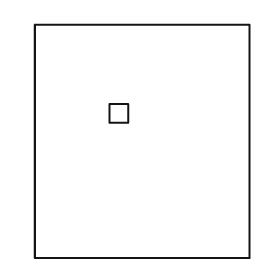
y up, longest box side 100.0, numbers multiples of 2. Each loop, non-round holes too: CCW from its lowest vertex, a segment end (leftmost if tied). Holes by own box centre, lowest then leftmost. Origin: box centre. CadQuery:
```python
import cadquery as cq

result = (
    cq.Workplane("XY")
    .moveTo(-46.0, -50.0)
    .lineTo(46.0, -50.0)
    .lineTo(46.0, 50.0)
    .lineTo(-46.0, 50.0)
    .close()
    .moveTo(-14.0, 8.0)
    .lineTo(-6.0, 8.0)
    .lineTo(-6.0, 16.0)
    .lineTo(-14.0, 16.0)
    .close()
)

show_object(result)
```